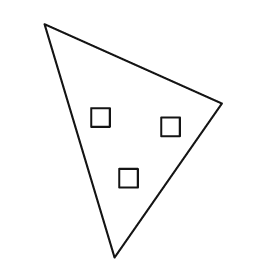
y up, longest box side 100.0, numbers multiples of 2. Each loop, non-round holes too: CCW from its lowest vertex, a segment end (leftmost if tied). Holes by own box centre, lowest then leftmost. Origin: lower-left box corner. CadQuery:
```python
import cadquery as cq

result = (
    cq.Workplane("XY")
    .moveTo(30.0, 0.0)
    .lineTo(76.0, 66.0)
    .lineTo(0.0, 100.0)
    .close()
    .moveTo(32.0, 30.0)
    .lineTo(40.0, 30.0)
    .lineTo(40.0, 38.0)
    .lineTo(32.0, 38.0)
    .close()
    .moveTo(50.0, 52.0)
    .lineTo(58.0, 52.0)
    .lineTo(58.0, 60.0)
    .lineTo(50.0, 60.0)
    .close()
    .moveTo(20.0, 56.0)
    .lineTo(28.0, 56.0)
    .lineTo(28.0, 64.0)
    .lineTo(20.0, 64.0)
    .close()
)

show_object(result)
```